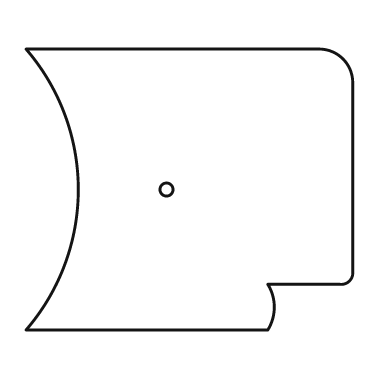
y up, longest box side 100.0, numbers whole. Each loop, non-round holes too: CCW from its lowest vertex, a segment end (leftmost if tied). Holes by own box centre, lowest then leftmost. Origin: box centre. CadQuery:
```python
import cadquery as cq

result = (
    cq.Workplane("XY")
    .moveTo(-50.0, -43.0)
    .lineTo(24.0, -43.0)
    .threePointArc((26.0, -36.0), (24.0, -29.0))
    .lineTo(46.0, -29.0)
    .threePointArc((49.0, -28.0), (50.0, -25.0))
    .lineTo(50.0, 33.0)
    .threePointArc((47.0, 40.0), (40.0, 43.0))
    .lineTo(-50.0, 43.0)
    .threePointArc((-34.0, 0.0), (-50.0, -43.0))
    .close()
    .moveTo(-7.0, 0.0)
    .circle(2.0)
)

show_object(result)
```